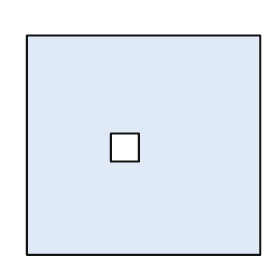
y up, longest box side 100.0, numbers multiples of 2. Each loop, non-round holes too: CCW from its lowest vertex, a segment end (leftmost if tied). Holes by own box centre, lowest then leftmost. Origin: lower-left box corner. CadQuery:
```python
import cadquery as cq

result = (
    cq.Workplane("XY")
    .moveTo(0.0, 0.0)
    .lineTo(100.0, 0.0)
    .lineTo(100.0, 94.0)
    .lineTo(0.0, 94.0)
    .close()
    .moveTo(36.0, 40.0)
    .lineTo(48.0, 40.0)
    .lineTo(48.0, 52.0)
    .lineTo(36.0, 52.0)
    .close()
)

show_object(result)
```